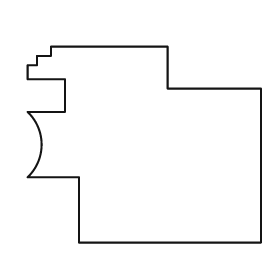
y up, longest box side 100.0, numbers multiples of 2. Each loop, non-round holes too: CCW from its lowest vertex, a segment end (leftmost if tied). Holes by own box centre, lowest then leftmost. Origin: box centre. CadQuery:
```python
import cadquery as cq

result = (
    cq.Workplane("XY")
    .moveTo(-28.0, -42.0)
    .lineTo(50.0, -42.0)
    .lineTo(50.0, 24.0)
    .lineTo(10.0, 24.0)
    .lineTo(10.0, 42.0)
    .lineTo(-40.0, 42.0)
    .lineTo(-40.0, 38.0)
    .lineTo(-46.0, 38.0)
    .lineTo(-46.0, 34.0)
    .lineTo(-50.0, 34.0)
    .lineTo(-50.0, 28.0)
    .lineTo(-34.0, 28.0)
    .lineTo(-34.0, 14.0)
    .lineTo(-50.0, 14.0)
    .threePointArc((-44.0, 0.0), (-50.0, -14.0))
    .lineTo(-28.0, -14.0)
    .close()
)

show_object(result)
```